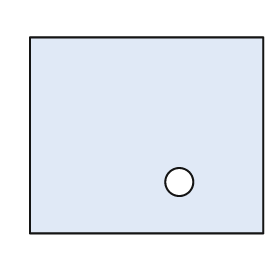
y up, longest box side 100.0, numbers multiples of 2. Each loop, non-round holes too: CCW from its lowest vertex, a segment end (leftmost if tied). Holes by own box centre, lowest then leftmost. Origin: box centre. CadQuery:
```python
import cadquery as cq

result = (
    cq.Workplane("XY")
    .moveTo(-50.0, -42.0)
    .lineTo(50.0, -42.0)
    .lineTo(50.0, 42.0)
    .lineTo(-50.0, 42.0)
    .close()
    .moveTo(14.0, -20.0)
    .circle(6.0)
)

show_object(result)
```